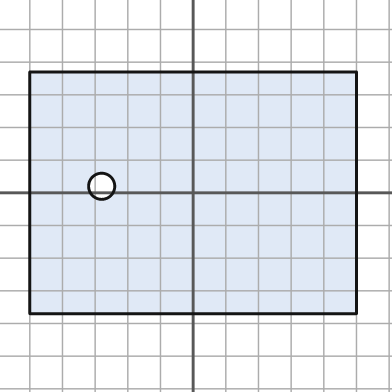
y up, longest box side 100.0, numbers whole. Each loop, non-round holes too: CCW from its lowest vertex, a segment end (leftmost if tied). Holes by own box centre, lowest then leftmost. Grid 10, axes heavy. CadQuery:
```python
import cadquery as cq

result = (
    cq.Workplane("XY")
    .moveTo(-50.0, -37.0)
    .lineTo(50.0, -37.0)
    .lineTo(50.0, 37.0)
    .lineTo(-50.0, 37.0)
    .close()
    .moveTo(-28.0, 2.0)
    .circle(4.0)
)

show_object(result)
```